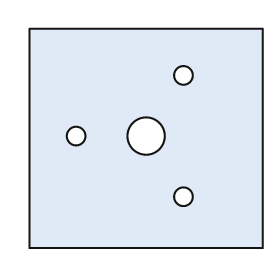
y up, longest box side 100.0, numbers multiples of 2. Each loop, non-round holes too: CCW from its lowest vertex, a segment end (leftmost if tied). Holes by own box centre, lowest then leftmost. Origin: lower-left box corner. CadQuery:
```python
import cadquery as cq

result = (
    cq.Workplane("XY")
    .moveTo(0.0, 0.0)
    .lineTo(100.0, 0.0)
    .lineTo(100.0, 94.0)
    .lineTo(0.0, 94.0)
    .close()
    .moveTo(66.0, 22.0)
    .circle(4.0)
    .moveTo(20.0, 48.0)
    .circle(4.0)
    .moveTo(50.0, 48.0)
    .circle(8.0)
    .moveTo(66.0, 74.0)
    .circle(4.0)
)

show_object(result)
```